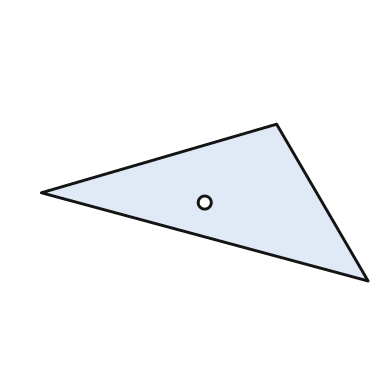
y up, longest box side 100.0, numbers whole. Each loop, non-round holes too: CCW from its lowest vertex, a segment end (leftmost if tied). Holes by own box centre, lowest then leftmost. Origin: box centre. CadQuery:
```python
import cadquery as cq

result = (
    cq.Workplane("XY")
    .moveTo(50.0, -24.0)
    .lineTo(22.0, 24.0)
    .lineTo(-50.0, 3.0)
    .close()
    .moveTo(0.0, 0.0)
    .circle(2.0)
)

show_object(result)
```